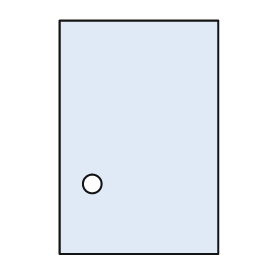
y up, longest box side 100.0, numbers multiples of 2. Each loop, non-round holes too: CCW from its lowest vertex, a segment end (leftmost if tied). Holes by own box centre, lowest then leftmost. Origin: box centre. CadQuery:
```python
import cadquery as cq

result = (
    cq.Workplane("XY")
    .moveTo(-34.0, -50.0)
    .lineTo(34.0, -50.0)
    .lineTo(34.0, 50.0)
    .lineTo(-34.0, 50.0)
    .close()
    .moveTo(-20.0, -20.0)
    .circle(4.0)
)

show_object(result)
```